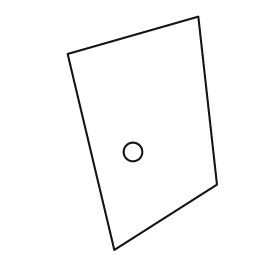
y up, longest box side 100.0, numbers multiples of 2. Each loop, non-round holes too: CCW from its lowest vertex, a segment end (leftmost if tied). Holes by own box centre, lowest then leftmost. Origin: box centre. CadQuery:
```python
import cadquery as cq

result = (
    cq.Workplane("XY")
    .moveTo(-12.0, -50.0)
    .lineTo(32.0, -22.0)
    .lineTo(24.0, 50.0)
    .lineTo(-32.0, 34.0)
    .close()
    .moveTo(-4.0, -8.0)
    .circle(4.0)
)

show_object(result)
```